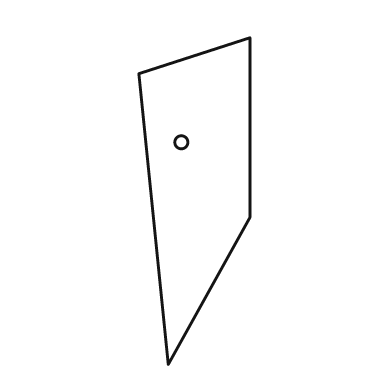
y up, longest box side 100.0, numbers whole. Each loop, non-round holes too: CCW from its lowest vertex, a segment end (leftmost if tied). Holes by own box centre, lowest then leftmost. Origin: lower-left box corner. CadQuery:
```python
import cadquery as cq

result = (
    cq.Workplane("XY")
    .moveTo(9.0, 0.0)
    .lineTo(34.0, 45.0)
    .lineTo(34.0, 100.0)
    .lineTo(0.0, 89.0)
    .close()
    .moveTo(13.0, 68.0)
    .circle(2.0)
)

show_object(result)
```